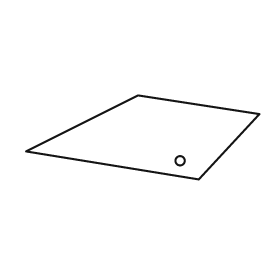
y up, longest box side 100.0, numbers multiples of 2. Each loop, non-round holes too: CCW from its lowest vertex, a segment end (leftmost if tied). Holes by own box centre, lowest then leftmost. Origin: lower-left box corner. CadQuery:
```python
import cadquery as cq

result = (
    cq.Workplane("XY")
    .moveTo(74.0, 0.0)
    .lineTo(100.0, 28.0)
    .lineTo(48.0, 36.0)
    .lineTo(0.0, 12.0)
    .close()
    .moveTo(66.0, 8.0)
    .circle(2.0)
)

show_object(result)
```